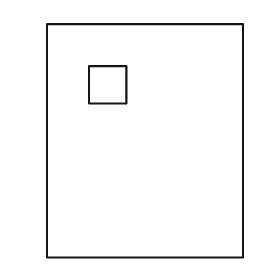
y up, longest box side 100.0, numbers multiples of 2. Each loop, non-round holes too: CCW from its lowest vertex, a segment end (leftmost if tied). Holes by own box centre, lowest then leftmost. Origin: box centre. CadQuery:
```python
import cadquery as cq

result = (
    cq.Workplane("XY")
    .moveTo(-42.0, -50.0)
    .lineTo(42.0, -50.0)
    .lineTo(42.0, 50.0)
    .lineTo(-42.0, 50.0)
    .close()
    .moveTo(-24.0, 16.0)
    .lineTo(-8.0, 16.0)
    .lineTo(-8.0, 32.0)
    .lineTo(-24.0, 32.0)
    .close()
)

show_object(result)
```